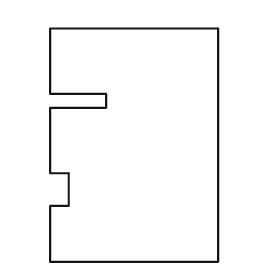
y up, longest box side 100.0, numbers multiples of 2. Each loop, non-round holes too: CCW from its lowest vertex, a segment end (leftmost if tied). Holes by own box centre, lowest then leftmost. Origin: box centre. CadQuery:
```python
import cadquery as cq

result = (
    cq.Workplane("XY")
    .moveTo(-36.0, -50.0)
    .lineTo(36.0, -50.0)
    .lineTo(36.0, 50.0)
    .lineTo(-36.0, 50.0)
    .lineTo(-36.0, 22.0)
    .lineTo(-12.0, 22.0)
    .lineTo(-12.0, 16.0)
    .lineTo(-36.0, 16.0)
    .lineTo(-36.0, -12.0)
    .lineTo(-28.0, -12.0)
    .lineTo(-28.0, -26.0)
    .lineTo(-36.0, -26.0)
    .close()
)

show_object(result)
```